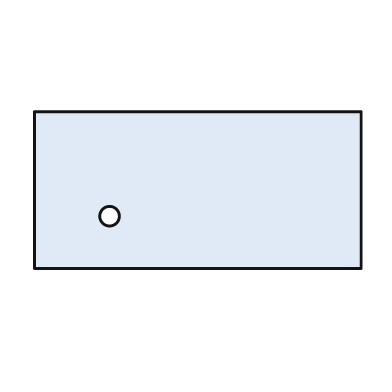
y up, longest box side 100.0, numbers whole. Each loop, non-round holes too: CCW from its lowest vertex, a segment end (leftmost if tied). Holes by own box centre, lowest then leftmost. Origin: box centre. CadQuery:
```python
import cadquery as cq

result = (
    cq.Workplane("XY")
    .moveTo(-50.0, -24.0)
    .lineTo(50.0, -24.0)
    .lineTo(50.0, 24.0)
    .lineTo(-50.0, 24.0)
    .close()
    .moveTo(-27.0, -8.0)
    .circle(3.0)
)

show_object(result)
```